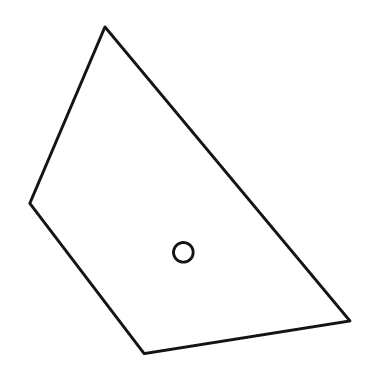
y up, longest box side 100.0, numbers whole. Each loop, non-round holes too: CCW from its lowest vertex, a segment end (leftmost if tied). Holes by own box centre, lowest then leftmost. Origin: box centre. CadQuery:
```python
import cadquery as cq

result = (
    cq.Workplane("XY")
    .moveTo(-14.0, -50.0)
    .lineTo(49.0, -40.0)
    .lineTo(-26.0, 50.0)
    .lineTo(-49.0, -4.0)
    .close()
    .moveTo(-2.0, -19.0)
    .circle(3.0)
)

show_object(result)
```